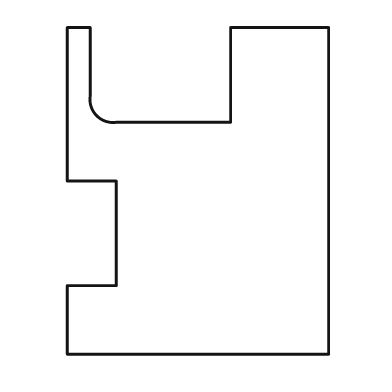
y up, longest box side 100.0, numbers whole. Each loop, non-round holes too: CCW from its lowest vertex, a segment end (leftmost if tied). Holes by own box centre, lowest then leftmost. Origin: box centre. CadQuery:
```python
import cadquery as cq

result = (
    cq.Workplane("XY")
    .moveTo(-40.0, -50.0)
    .lineTo(40.0, -50.0)
    .lineTo(40.0, 50.0)
    .lineTo(10.0, 50.0)
    .lineTo(10.0, 21.0)
    .lineTo(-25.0, 21.0)
    .threePointArc((-31.0, 23.0), (-33.0, 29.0))
    .lineTo(-33.0, 50.0)
    .lineTo(-40.0, 50.0)
    .lineTo(-40.0, 3.0)
    .lineTo(-25.0, 3.0)
    .lineTo(-25.0, -29.0)
    .lineTo(-40.0, -29.0)
    .close()
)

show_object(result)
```